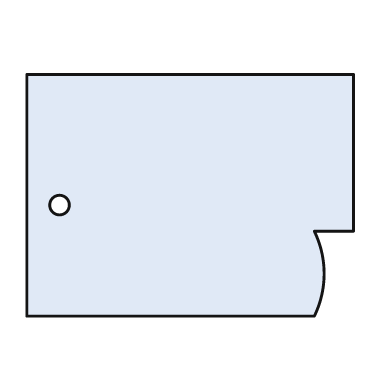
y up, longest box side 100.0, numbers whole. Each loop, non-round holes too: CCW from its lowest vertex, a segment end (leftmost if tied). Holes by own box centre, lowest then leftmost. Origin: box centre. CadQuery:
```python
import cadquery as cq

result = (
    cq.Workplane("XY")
    .moveTo(-50.0, -37.0)
    .lineTo(38.0, -37.0)
    .threePointArc((41.0, -24.0), (38.0, -11.0))
    .lineTo(50.0, -11.0)
    .lineTo(50.0, 37.0)
    .lineTo(-50.0, 37.0)
    .close()
    .moveTo(-40.0, -3.0)
    .circle(3.0)
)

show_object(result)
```